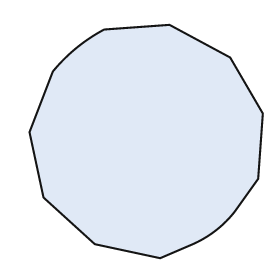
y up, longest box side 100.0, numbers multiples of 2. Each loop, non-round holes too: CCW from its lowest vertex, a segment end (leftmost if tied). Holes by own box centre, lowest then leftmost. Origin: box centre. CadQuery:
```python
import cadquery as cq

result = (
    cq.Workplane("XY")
    .moveTo(6.0, -50.0)
    .lineTo(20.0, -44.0)
    .threePointArc((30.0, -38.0), (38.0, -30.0))
    .lineTo(48.0, -16.0)
    .lineTo(50.0, 12.0)
    .lineTo(36.0, 36.0)
    .lineTo(10.0, 50.0)
    .lineTo(-18.0, 48.0)
    .threePointArc((-30.0, 40.0), (-40.0, 30.0))
    .lineTo(-50.0, 4.0)
    .lineTo(-44.0, -24.0)
    .lineTo(-22.0, -44.0)
    .close()
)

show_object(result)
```